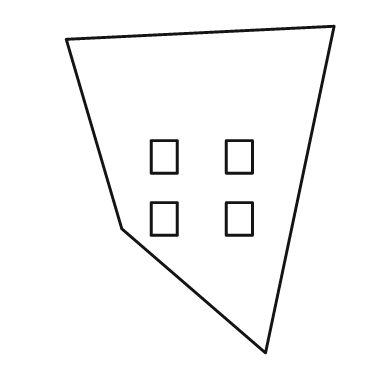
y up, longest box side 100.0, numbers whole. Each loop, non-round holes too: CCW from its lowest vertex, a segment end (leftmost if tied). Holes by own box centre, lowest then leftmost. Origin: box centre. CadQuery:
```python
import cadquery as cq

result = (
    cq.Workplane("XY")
    .moveTo(20.0, -50.0)
    .lineTo(41.0, 50.0)
    .lineTo(-41.0, 46.0)
    .lineTo(-24.0, -12.0)
    .close()
    .moveTo(-15.0, -14.0)
    .lineTo(-7.0, -14.0)
    .lineTo(-7.0, -4.0)
    .lineTo(-15.0, -4.0)
    .close()
    .moveTo(8.0, -14.0)
    .lineTo(16.0, -14.0)
    .lineTo(16.0, -4.0)
    .lineTo(8.0, -4.0)
    .close()
    .moveTo(-15.0, 5.0)
    .lineTo(-7.0, 5.0)
    .lineTo(-7.0, 15.0)
    .lineTo(-15.0, 15.0)
    .close()
    .moveTo(8.0, 5.0)
    .lineTo(16.0, 5.0)
    .lineTo(16.0, 15.0)
    .lineTo(8.0, 15.0)
    .close()
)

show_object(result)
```